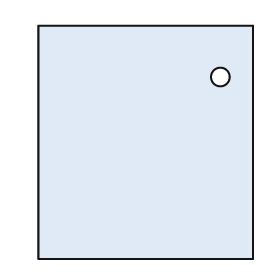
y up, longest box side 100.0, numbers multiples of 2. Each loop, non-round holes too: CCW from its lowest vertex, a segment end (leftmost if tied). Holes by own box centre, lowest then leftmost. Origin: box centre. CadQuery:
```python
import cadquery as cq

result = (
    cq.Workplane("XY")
    .moveTo(-46.0, -50.0)
    .lineTo(46.0, -50.0)
    .lineTo(46.0, 50.0)
    .lineTo(-46.0, 50.0)
    .close()
    .moveTo(32.0, 28.0)
    .circle(4.0)
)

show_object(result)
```